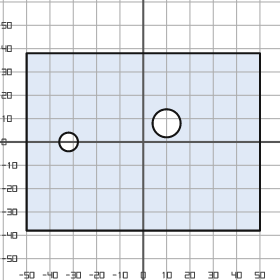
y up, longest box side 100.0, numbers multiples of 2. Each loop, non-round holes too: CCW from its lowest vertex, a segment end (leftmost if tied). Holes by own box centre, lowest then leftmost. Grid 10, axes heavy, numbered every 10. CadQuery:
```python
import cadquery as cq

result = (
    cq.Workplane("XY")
    .moveTo(-50.0, -38.0)
    .lineTo(50.0, -38.0)
    .lineTo(50.0, 38.0)
    .lineTo(-50.0, 38.0)
    .close()
    .moveTo(-32.0, 0.0)
    .circle(4.0)
    .moveTo(10.0, 8.0)
    .circle(6.0)
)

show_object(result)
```